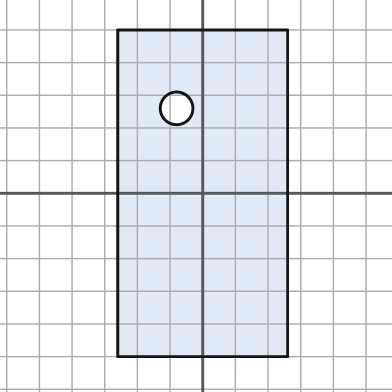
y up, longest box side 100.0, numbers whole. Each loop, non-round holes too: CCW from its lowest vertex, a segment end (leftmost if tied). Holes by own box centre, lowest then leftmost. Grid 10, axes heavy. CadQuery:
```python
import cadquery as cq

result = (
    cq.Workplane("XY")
    .moveTo(-26.0, -50.0)
    .lineTo(26.0, -50.0)
    .lineTo(26.0, 50.0)
    .lineTo(-26.0, 50.0)
    .close()
    .moveTo(-8.0, 26.0)
    .circle(5.0)
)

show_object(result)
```